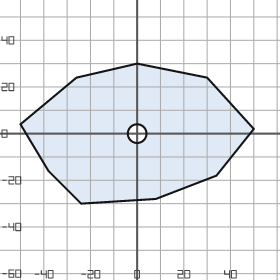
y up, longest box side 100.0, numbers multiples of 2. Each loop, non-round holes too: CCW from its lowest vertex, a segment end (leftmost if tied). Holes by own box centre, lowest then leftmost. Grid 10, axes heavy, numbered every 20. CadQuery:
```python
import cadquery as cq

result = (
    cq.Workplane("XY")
    .moveTo(-24.0, -30.0)
    .lineTo(8.0, -28.0)
    .lineTo(34.0, -18.0)
    .lineTo(50.0, 2.0)
    .lineTo(30.0, 24.0)
    .lineTo(0.0, 30.0)
    .lineTo(-26.0, 24.0)
    .lineTo(-50.0, 4.0)
    .lineTo(-38.0, -16.0)
    .close()
    .moveTo(0.0, 0.0)
    .circle(4.0)
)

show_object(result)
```